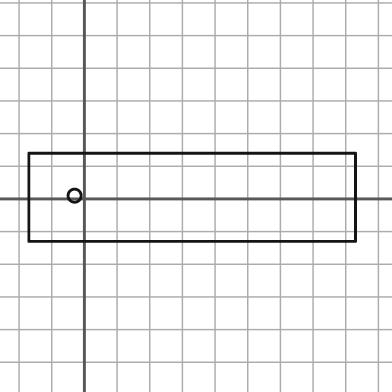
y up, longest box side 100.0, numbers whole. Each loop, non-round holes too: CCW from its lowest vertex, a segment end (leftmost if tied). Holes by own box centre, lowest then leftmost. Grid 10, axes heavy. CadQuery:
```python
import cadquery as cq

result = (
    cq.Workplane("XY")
    .moveTo(-17.0, -13.0)
    .lineTo(83.0, -13.0)
    .lineTo(83.0, 14.0)
    .lineTo(-17.0, 14.0)
    .close()
    .moveTo(-3.0, 1.0)
    .circle(2.0)
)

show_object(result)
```